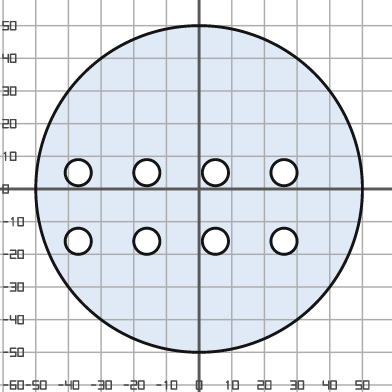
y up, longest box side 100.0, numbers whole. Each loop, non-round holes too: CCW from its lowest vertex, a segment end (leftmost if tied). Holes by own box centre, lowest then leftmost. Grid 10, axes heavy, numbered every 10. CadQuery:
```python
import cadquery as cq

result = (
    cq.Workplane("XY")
    .moveTo(0.0, 0.0)
    .circle(50.0)
    .moveTo(-37.0, -16.0)
    .circle(4.0)
    .moveTo(-16.0, -16.0)
    .circle(4.0)
    .moveTo(5.0, -16.0)
    .circle(4.0)
    .moveTo(26.0, -16.0)
    .circle(4.0)
    .moveTo(-37.0, 5.0)
    .circle(4.0)
    .moveTo(-16.0, 5.0)
    .circle(4.0)
    .moveTo(5.0, 5.0)
    .circle(4.0)
    .moveTo(26.0, 5.0)
    .circle(4.0)
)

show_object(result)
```